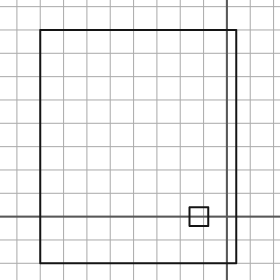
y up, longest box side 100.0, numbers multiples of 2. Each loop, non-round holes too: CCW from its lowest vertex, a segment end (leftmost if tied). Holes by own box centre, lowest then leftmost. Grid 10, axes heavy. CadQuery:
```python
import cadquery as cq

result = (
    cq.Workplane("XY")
    .moveTo(-80.0, -20.0)
    .lineTo(4.0, -20.0)
    .lineTo(4.0, 80.0)
    .lineTo(-80.0, 80.0)
    .close()
    .moveTo(-16.0, -4.0)
    .lineTo(-8.0, -4.0)
    .lineTo(-8.0, 4.0)
    .lineTo(-16.0, 4.0)
    .close()
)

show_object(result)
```